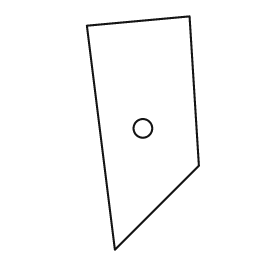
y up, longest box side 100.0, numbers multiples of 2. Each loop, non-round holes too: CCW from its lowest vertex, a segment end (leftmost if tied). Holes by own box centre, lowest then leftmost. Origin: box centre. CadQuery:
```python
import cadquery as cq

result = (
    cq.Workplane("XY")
    .moveTo(-12.0, -50.0)
    .lineTo(24.0, -14.0)
    .lineTo(20.0, 50.0)
    .lineTo(-24.0, 46.0)
    .close()
    .moveTo(0.0, 2.0)
    .circle(4.0)
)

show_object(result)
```